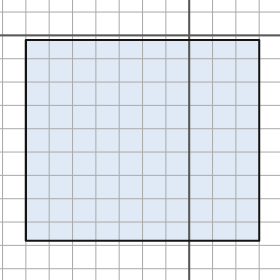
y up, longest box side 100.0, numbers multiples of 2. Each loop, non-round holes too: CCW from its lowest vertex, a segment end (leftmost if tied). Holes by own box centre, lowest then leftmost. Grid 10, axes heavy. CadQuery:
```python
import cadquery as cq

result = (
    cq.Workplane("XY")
    .moveTo(-70.0, -88.0)
    .lineTo(30.0, -88.0)
    .lineTo(30.0, -2.0)
    .lineTo(-70.0, -2.0)
    .close()
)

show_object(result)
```